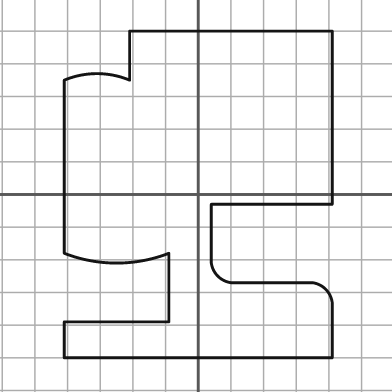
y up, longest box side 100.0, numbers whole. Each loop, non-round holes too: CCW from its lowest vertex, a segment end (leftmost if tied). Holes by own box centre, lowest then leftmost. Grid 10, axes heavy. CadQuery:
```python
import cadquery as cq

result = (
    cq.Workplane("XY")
    .moveTo(-41.0, -50.0)
    .lineTo(41.0, -50.0)
    .lineTo(41.0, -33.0)
    .threePointArc((39.0, -29.0), (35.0, -27.0))
    .lineTo(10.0, -27.0)
    .threePointArc((6.0, -25.0), (4.0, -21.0))
    .lineTo(4.0, -3.0)
    .lineTo(41.0, -3.0)
    .lineTo(41.0, 50.0)
    .lineTo(-21.0, 50.0)
    .lineTo(-21.0, 35.0)
    .threePointArc((-31.0, 37.0), (-41.0, 35.0))
    .lineTo(-41.0, -18.0)
    .threePointArc((-25.0, -21.0), (-9.0, -18.0))
    .lineTo(-9.0, -39.0)
    .lineTo(-41.0, -39.0)
    .close()
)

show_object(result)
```